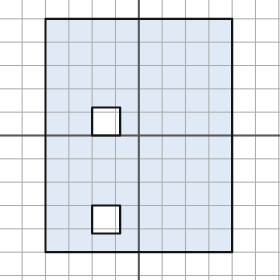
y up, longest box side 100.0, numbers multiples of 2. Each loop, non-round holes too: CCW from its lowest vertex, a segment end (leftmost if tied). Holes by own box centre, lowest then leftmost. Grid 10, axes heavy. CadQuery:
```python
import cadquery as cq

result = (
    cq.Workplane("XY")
    .moveTo(-40.0, -50.0)
    .lineTo(40.0, -50.0)
    .lineTo(40.0, 50.0)
    .lineTo(-40.0, 50.0)
    .close()
    .moveTo(-20.0, -42.0)
    .lineTo(-8.0, -42.0)
    .lineTo(-8.0, -30.0)
    .lineTo(-20.0, -30.0)
    .close()
    .moveTo(-20.0, 0.0)
    .lineTo(-8.0, 0.0)
    .lineTo(-8.0, 12.0)
    .lineTo(-20.0, 12.0)
    .close()
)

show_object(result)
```